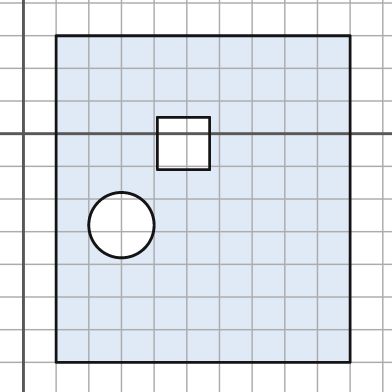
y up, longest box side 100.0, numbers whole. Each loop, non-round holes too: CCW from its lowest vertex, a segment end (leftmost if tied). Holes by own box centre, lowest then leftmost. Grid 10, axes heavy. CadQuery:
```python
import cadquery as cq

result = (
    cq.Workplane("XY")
    .moveTo(10.0, -70.0)
    .lineTo(100.0, -70.0)
    .lineTo(100.0, 30.0)
    .lineTo(10.0, 30.0)
    .close()
    .moveTo(30.0, -28.0)
    .circle(10.0)
    .moveTo(41.0, -11.0)
    .lineTo(57.0, -11.0)
    .lineTo(57.0, 5.0)
    .lineTo(41.0, 5.0)
    .close()
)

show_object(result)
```